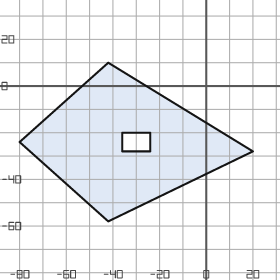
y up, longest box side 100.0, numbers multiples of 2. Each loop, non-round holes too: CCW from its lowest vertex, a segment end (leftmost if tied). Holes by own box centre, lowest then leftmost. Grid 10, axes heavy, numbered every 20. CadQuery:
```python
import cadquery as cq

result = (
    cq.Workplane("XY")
    .moveTo(-42.0, -58.0)
    .lineTo(20.0, -28.0)
    .lineTo(-42.0, 10.0)
    .lineTo(-80.0, -24.0)
    .close()
    .moveTo(-36.0, -28.0)
    .lineTo(-24.0, -28.0)
    .lineTo(-24.0, -20.0)
    .lineTo(-36.0, -20.0)
    .close()
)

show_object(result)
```